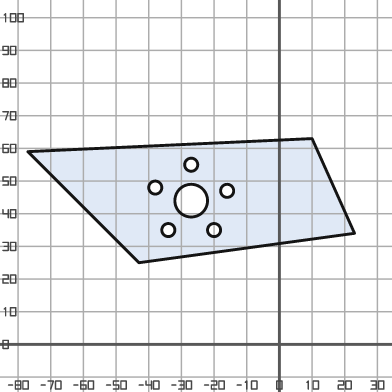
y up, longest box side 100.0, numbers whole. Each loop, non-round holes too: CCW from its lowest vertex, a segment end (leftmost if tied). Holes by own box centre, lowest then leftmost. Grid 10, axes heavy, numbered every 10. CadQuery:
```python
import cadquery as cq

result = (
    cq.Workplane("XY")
    .moveTo(-43.0, 25.0)
    .lineTo(23.0, 34.0)
    .lineTo(10.0, 63.0)
    .lineTo(-77.0, 59.0)
    .close()
    .moveTo(-34.0, 35.0)
    .circle(2.0)
    .moveTo(-20.0, 35.0)
    .circle(2.0)
    .moveTo(-27.0, 44.0)
    .circle(5.0)
    .moveTo(-16.0, 47.0)
    .circle(2.0)
    .moveTo(-38.0, 48.0)
    .circle(2.0)
    .moveTo(-27.0, 55.0)
    .circle(2.0)
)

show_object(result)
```